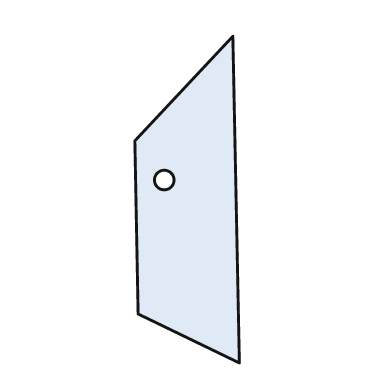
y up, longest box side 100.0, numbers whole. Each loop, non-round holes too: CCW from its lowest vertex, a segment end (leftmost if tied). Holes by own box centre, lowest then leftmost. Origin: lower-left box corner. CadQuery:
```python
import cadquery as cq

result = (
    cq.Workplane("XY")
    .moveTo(32.0, 0.0)
    .lineTo(30.0, 100.0)
    .lineTo(0.0, 68.0)
    .lineTo(1.0, 15.0)
    .close()
    .moveTo(9.0, 56.0)
    .circle(3.0)
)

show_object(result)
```